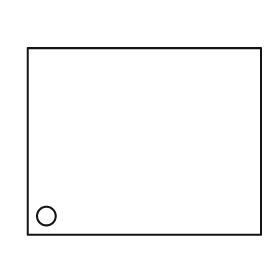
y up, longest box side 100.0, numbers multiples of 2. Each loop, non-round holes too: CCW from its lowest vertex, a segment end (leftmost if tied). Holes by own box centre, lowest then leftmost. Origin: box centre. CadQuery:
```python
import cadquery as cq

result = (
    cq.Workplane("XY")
    .moveTo(-50.0, -40.0)
    .lineTo(50.0, -40.0)
    .lineTo(50.0, 40.0)
    .lineTo(-50.0, 40.0)
    .close()
    .moveTo(-42.0, -32.0)
    .circle(4.0)
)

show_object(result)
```